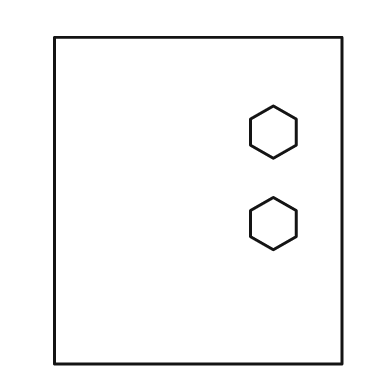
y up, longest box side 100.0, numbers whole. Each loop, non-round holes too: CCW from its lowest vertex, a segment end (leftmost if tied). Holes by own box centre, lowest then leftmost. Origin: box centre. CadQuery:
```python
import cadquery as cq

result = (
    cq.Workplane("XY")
    .moveTo(-44.0, -50.0)
    .lineTo(44.0, -50.0)
    .lineTo(44.0, 50.0)
    .lineTo(-44.0, 50.0)
    .close()
    .moveTo(23.0, -15.0)
    .lineTo(30.0, -11.0)
    .lineTo(30.0, -3.0)
    .lineTo(23.0, 1.0)
    .lineTo(16.0, -3.0)
    .lineTo(16.0, -11.0)
    .close()
    .moveTo(23.0, 13.0)
    .lineTo(30.0, 17.0)
    .lineTo(30.0, 25.0)
    .lineTo(23.0, 29.0)
    .lineTo(16.0, 25.0)
    .lineTo(16.0, 17.0)
    .close()
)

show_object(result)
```